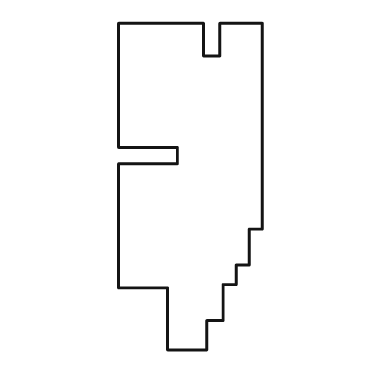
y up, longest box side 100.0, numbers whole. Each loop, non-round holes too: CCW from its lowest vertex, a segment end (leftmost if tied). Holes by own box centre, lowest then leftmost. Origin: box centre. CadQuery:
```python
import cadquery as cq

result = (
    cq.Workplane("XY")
    .moveTo(-7.0, -50.0)
    .lineTo(5.0, -50.0)
    .lineTo(5.0, -41.0)
    .lineTo(10.0, -41.0)
    .lineTo(10.0, -30.0)
    .lineTo(14.0, -30.0)
    .lineTo(14.0, -24.0)
    .lineTo(18.0, -24.0)
    .lineTo(18.0, -13.0)
    .lineTo(22.0, -13.0)
    .lineTo(22.0, 50.0)
    .lineTo(9.0, 50.0)
    .lineTo(9.0, 40.0)
    .lineTo(4.0, 40.0)
    .lineTo(4.0, 50.0)
    .lineTo(-22.0, 50.0)
    .lineTo(-22.0, 12.0)
    .lineTo(-4.0, 12.0)
    .lineTo(-4.0, 7.0)
    .lineTo(-22.0, 7.0)
    .lineTo(-22.0, -31.0)
    .lineTo(-7.0, -31.0)
    .close()
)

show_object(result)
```